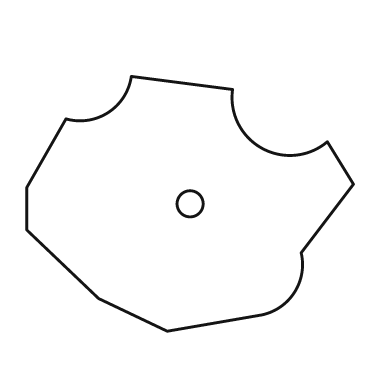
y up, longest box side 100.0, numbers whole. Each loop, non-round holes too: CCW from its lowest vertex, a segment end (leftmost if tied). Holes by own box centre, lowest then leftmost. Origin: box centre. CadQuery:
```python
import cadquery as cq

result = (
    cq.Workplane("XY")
    .moveTo(-7.0, -39.0)
    .lineTo(22.0, -34.0)
    .threePointArc((32.0, -27.0), (34.0, -15.0))
    .lineTo(50.0, 6.0)
    .lineTo(42.0, 19.0)
    .threePointArc((22.0, 17.0), (13.0, 35.0))
    .lineTo(-18.0, 39.0)
    .threePointArc((-25.0, 28.0), (-38.0, 26.0))
    .lineTo(-50.0, 5.0)
    .lineTo(-50.0, -8.0)
    .lineTo(-28.0, -29.0)
    .close()
    .moveTo(0.0, 0.0)
    .circle(4.0)
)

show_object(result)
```